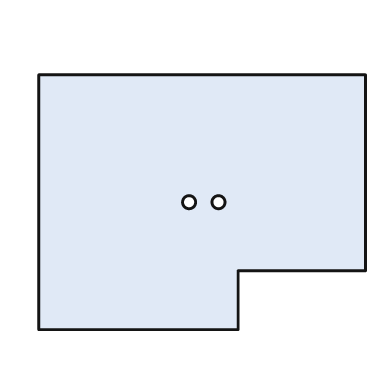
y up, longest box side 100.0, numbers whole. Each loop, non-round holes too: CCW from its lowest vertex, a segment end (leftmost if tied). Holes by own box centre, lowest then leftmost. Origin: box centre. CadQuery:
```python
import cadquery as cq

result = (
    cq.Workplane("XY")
    .moveTo(-50.0, -39.0)
    .lineTo(11.0, -39.0)
    .lineTo(11.0, -21.0)
    .lineTo(50.0, -21.0)
    .lineTo(50.0, 39.0)
    .lineTo(-50.0, 39.0)
    .close()
    .moveTo(-4.0, 0.0)
    .circle(2.0)
    .moveTo(5.0, 0.0)
    .circle(2.0)
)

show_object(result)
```